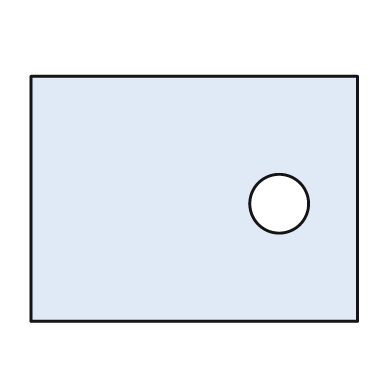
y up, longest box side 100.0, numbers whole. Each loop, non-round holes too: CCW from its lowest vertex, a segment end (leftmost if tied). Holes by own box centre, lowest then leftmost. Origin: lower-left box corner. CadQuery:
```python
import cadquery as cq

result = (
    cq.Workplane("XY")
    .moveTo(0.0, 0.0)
    .lineTo(100.0, 0.0)
    .lineTo(100.0, 75.0)
    .lineTo(0.0, 75.0)
    .close()
    .moveTo(76.0, 36.0)
    .circle(9.0)
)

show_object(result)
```